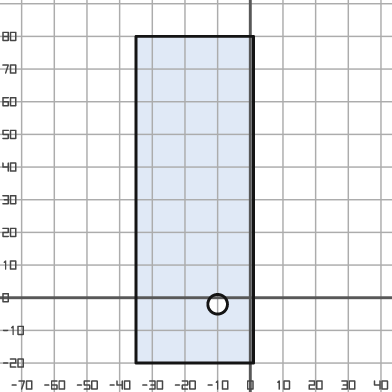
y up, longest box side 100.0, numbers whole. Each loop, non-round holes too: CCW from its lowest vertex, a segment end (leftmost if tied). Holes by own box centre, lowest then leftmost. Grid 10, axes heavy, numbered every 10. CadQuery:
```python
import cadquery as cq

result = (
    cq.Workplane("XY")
    .moveTo(-35.0, -20.0)
    .lineTo(1.0, -20.0)
    .lineTo(1.0, 80.0)
    .lineTo(-35.0, 80.0)
    .close()
    .moveTo(-10.0, -2.0)
    .circle(3.0)
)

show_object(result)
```